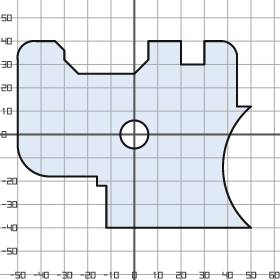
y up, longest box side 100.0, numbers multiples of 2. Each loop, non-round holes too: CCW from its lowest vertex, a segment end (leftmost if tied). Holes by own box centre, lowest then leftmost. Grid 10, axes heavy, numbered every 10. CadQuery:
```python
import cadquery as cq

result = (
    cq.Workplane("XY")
    .moveTo(-12.0, -40.0)
    .lineTo(50.0, -40.0)
    .threePointArc((38.0, -14.0), (50.0, 12.0))
    .lineTo(44.0, 12.0)
    .lineTo(44.0, 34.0)
    .threePointArc((42.0, 38.0), (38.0, 40.0))
    .lineTo(30.0, 40.0)
    .lineTo(30.0, 30.0)
    .lineTo(20.0, 30.0)
    .lineTo(20.0, 40.0)
    .lineTo(6.0, 40.0)
    .lineTo(6.0, 32.0)
    .lineTo(0.0, 26.0)
    .lineTo(-24.0, 26.0)
    .lineTo(-30.0, 32.0)
    .lineTo(-30.0, 36.0)
    .lineTo(-34.0, 40.0)
    .lineTo(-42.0, 40.0)
    .threePointArc((-48.0, 38.0), (-50.0, 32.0))
    .lineTo(-50.0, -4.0)
    .threePointArc((-46.0, -14.0), (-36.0, -18.0))
    .lineTo(-16.0, -18.0)
    .lineTo(-16.0, -22.0)
    .lineTo(-12.0, -22.0)
    .close()
    .moveTo(0.0, 0.0)
    .circle(6.0)
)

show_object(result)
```